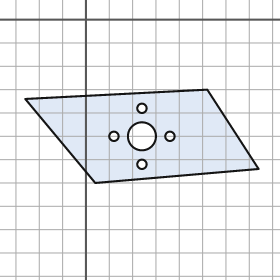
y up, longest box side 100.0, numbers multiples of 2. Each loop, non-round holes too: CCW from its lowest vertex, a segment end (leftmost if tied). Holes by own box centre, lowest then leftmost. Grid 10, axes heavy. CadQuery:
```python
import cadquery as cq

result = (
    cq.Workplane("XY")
    .moveTo(4.0, -70.0)
    .lineTo(74.0, -64.0)
    .lineTo(52.0, -30.0)
    .lineTo(-26.0, -34.0)
    .close()
    .moveTo(24.0, -62.0)
    .circle(2.0)
    .moveTo(12.0, -50.0)
    .circle(2.0)
    .moveTo(24.0, -50.0)
    .circle(6.0)
    .moveTo(36.0, -50.0)
    .circle(2.0)
    .moveTo(24.0, -38.0)
    .circle(2.0)
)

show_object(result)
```